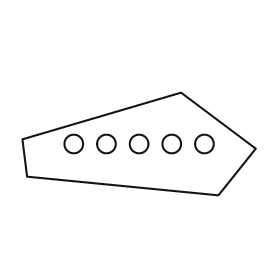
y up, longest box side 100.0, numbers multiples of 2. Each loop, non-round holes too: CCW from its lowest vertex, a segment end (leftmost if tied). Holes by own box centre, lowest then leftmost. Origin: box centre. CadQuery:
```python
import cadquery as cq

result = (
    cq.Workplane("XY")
    .moveTo(34.0, -22.0)
    .lineTo(50.0, -2.0)
    .lineTo(18.0, 22.0)
    .lineTo(-50.0, 2.0)
    .lineTo(-48.0, -14.0)
    .close()
    .moveTo(-28.0, 0.0)
    .circle(4.0)
    .moveTo(-14.0, 0.0)
    .circle(4.0)
    .moveTo(0.0, 0.0)
    .circle(4.0)
    .moveTo(14.0, 0.0)
    .circle(4.0)
    .moveTo(28.0, 0.0)
    .circle(4.0)
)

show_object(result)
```